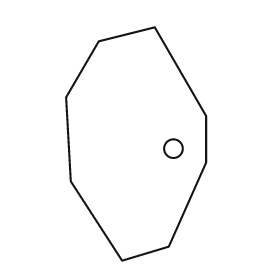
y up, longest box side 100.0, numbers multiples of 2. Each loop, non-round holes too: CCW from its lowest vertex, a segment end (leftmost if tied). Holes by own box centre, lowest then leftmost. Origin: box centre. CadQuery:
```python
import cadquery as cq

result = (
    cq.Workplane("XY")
    .moveTo(-6.0, -50.0)
    .lineTo(14.0, -44.0)
    .lineTo(30.0, -8.0)
    .lineTo(30.0, 12.0)
    .lineTo(8.0, 50.0)
    .lineTo(-16.0, 44.0)
    .lineTo(-30.0, 20.0)
    .lineTo(-28.0, -16.0)
    .close()
    .moveTo(16.0, -2.0)
    .circle(4.0)
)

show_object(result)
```